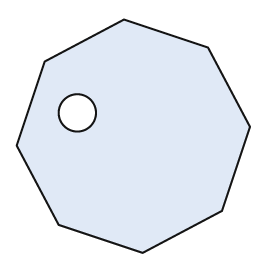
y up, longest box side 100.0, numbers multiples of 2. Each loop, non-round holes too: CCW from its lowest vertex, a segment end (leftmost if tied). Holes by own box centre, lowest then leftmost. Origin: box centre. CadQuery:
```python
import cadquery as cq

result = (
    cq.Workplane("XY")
    .moveTo(4.0, -50.0)
    .lineTo(38.0, -32.0)
    .lineTo(50.0, 4.0)
    .lineTo(32.0, 38.0)
    .lineTo(-4.0, 50.0)
    .lineTo(-38.0, 32.0)
    .lineTo(-50.0, -4.0)
    .lineTo(-32.0, -38.0)
    .close()
    .moveTo(-24.0, 10.0)
    .circle(8.0)
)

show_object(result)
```